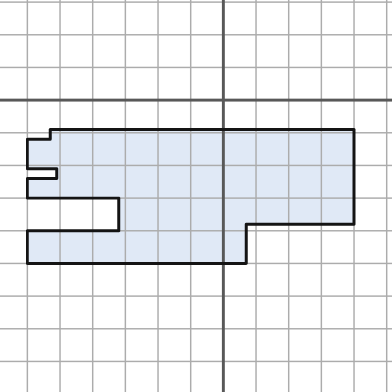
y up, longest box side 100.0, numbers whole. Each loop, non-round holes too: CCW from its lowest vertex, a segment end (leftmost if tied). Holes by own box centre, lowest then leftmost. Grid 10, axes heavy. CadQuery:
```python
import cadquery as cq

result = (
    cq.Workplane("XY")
    .moveTo(-60.0, -50.0)
    .lineTo(7.0, -50.0)
    .lineTo(7.0, -38.0)
    .lineTo(40.0, -38.0)
    .lineTo(40.0, -9.0)
    .lineTo(-53.0, -9.0)
    .lineTo(-53.0, -12.0)
    .lineTo(-60.0, -12.0)
    .lineTo(-60.0, -21.0)
    .lineTo(-51.0, -21.0)
    .lineTo(-51.0, -24.0)
    .lineTo(-60.0, -24.0)
    .lineTo(-60.0, -30.0)
    .lineTo(-32.0, -30.0)
    .lineTo(-32.0, -40.0)
    .lineTo(-60.0, -40.0)
    .close()
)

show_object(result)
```